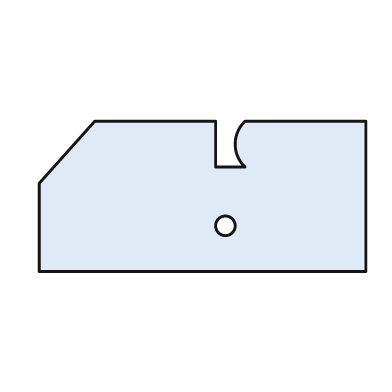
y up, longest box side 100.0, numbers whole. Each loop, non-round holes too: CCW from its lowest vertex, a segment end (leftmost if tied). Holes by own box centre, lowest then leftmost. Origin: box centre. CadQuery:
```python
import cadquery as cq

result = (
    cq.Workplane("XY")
    .moveTo(-50.0, -23.0)
    .lineTo(50.0, -23.0)
    .lineTo(50.0, 23.0)
    .lineTo(13.0, 23.0)
    .threePointArc((10.0, 16.0), (13.0, 9.0))
    .lineTo(4.0, 9.0)
    .lineTo(4.0, 23.0)
    .lineTo(-33.0, 23.0)
    .lineTo(-50.0, 4.0)
    .close()
    .moveTo(7.0, -9.0)
    .circle(3.0)
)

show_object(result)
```